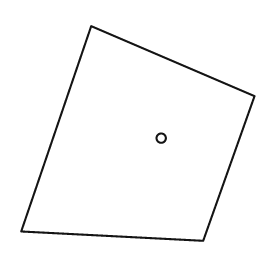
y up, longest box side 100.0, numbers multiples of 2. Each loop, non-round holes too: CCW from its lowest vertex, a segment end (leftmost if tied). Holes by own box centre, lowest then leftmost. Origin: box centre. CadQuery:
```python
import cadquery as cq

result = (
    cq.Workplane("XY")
    .moveTo(28.0, -46.0)
    .lineTo(50.0, 16.0)
    .lineTo(-20.0, 46.0)
    .lineTo(-50.0, -42.0)
    .close()
    .moveTo(10.0, -2.0)
    .circle(2.0)
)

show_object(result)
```